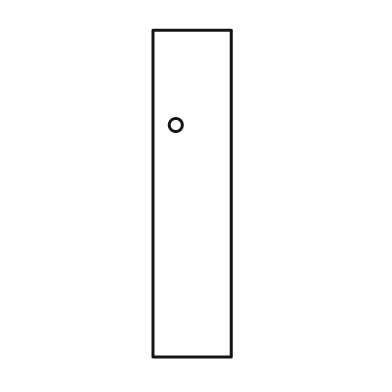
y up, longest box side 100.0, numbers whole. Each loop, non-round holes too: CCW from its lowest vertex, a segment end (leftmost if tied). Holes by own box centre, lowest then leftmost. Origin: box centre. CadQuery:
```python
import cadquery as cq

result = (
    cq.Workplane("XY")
    .moveTo(-12.0, -50.0)
    .lineTo(12.0, -50.0)
    .lineTo(12.0, 50.0)
    .lineTo(-12.0, 50.0)
    .close()
    .moveTo(-5.0, 21.0)
    .circle(2.0)
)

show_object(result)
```